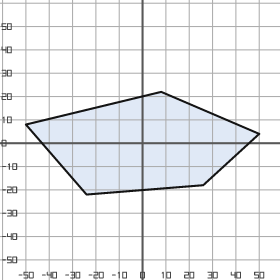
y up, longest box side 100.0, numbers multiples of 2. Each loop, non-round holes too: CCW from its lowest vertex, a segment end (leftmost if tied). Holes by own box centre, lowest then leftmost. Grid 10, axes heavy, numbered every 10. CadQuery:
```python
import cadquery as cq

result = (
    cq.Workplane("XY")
    .moveTo(-24.0, -22.0)
    .lineTo(26.0, -18.0)
    .lineTo(50.0, 4.0)
    .lineTo(8.0, 22.0)
    .lineTo(-50.0, 8.0)
    .close()
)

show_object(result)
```